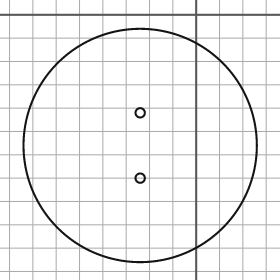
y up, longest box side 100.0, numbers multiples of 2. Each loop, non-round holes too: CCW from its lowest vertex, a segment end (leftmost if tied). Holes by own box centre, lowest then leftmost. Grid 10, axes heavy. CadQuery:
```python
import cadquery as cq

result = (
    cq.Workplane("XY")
    .moveTo(-24.0, -56.0)
    .circle(50.0)
    .moveTo(-24.0, -70.0)
    .circle(2.0)
    .moveTo(-24.0, -42.0)
    .circle(2.0)
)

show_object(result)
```